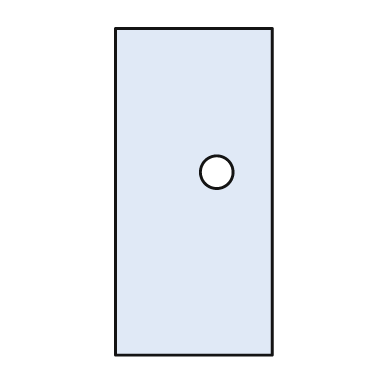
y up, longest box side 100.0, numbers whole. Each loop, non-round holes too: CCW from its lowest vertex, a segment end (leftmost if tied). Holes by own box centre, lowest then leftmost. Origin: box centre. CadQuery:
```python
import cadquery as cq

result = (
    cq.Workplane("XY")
    .moveTo(-24.0, -50.0)
    .lineTo(24.0, -50.0)
    .lineTo(24.0, 50.0)
    .lineTo(-24.0, 50.0)
    .close()
    .moveTo(7.0, 6.0)
    .circle(5.0)
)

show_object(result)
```